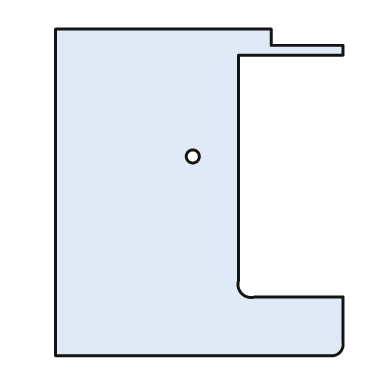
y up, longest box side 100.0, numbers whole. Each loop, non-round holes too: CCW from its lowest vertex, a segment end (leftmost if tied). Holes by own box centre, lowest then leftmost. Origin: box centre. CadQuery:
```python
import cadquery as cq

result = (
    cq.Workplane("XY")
    .moveTo(-44.0, -50.0)
    .lineTo(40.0, -50.0)
    .threePointArc((43.0, -49.0), (44.0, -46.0))
    .lineTo(44.0, -32.0)
    .lineTo(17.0, -32.0)
    .threePointArc((13.0, -31.0), (12.0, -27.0))
    .lineTo(12.0, 42.0)
    .lineTo(44.0, 42.0)
    .lineTo(44.0, 45.0)
    .lineTo(22.0, 45.0)
    .lineTo(22.0, 50.0)
    .lineTo(-44.0, 50.0)
    .close()
    .moveTo(-2.0, 11.0)
    .circle(2.0)
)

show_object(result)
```